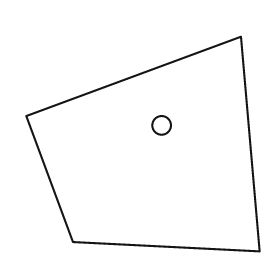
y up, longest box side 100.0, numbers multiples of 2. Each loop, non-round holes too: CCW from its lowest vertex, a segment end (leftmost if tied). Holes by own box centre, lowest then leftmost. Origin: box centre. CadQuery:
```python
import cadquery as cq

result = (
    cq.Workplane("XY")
    .moveTo(50.0, -46.0)
    .lineTo(42.0, 46.0)
    .lineTo(-50.0, 12.0)
    .lineTo(-30.0, -42.0)
    .close()
    .moveTo(8.0, 8.0)
    .circle(4.0)
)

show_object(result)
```